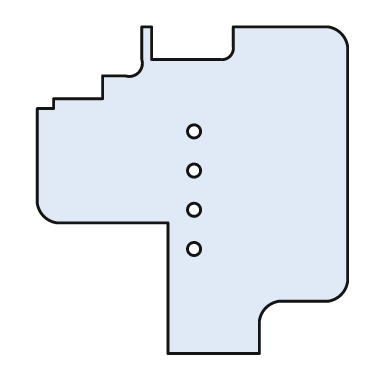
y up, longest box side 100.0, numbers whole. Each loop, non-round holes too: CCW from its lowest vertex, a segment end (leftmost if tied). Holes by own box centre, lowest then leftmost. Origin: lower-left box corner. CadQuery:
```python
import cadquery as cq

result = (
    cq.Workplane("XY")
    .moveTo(40.0, 0.0)
    .lineTo(68.0, 0.0)
    .lineTo(68.0, 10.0)
    .threePointArc((70.0, 14.0), (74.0, 16.0))
    .lineTo(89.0, 16.0)
    .threePointArc((93.0, 18.0), (95.0, 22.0))
    .lineTo(95.0, 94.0)
    .threePointArc((93.0, 98.0), (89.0, 100.0))
    .lineTo(60.0, 100.0)
    .lineTo(60.0, 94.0)
    .threePointArc((59.0, 91.0), (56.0, 90.0))
    .lineTo(35.0, 90.0)
    .lineTo(35.0, 100.0)
    .lineTo(32.0, 100.0)
    .lineTo(32.0, 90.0)
    .threePointArc((31.0, 86.0), (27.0, 85.0))
    .lineTo(20.0, 85.0)
    .lineTo(20.0, 78.0)
    .lineTo(5.0, 78.0)
    .lineTo(5.0, 75.0)
    .lineTo(0.0, 75.0)
    .lineTo(0.0, 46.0)
    .threePointArc((2.0, 42.0), (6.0, 40.0))
    .lineTo(40.0, 40.0)
    .close()
    .moveTo(48.0, 32.0)
    .circle(2.0)
    .moveTo(48.0, 44.0)
    .circle(2.0)
    .moveTo(48.0, 56.0)
    .circle(2.0)
    .moveTo(48.0, 68.0)
    .circle(2.0)
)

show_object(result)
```